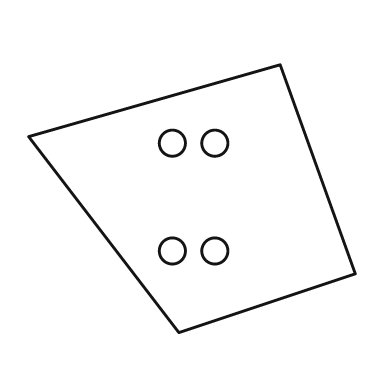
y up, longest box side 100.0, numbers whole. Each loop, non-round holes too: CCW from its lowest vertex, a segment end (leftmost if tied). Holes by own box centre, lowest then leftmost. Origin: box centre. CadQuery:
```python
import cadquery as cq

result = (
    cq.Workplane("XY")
    .moveTo(-4.0, -41.0)
    .lineTo(50.0, -23.0)
    .lineTo(27.0, 41.0)
    .lineTo(-50.0, 19.0)
    .close()
    .moveTo(-6.0, -16.0)
    .circle(4.0)
    .moveTo(7.0, -16.0)
    .circle(4.0)
    .moveTo(-6.0, 17.0)
    .circle(4.0)
    .moveTo(7.0, 17.0)
    .circle(4.0)
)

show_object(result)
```